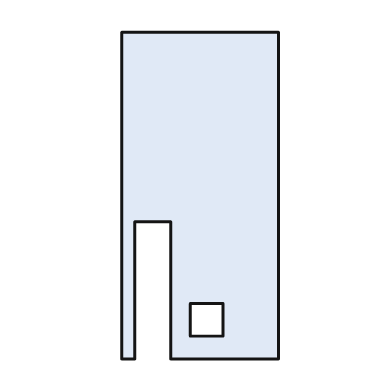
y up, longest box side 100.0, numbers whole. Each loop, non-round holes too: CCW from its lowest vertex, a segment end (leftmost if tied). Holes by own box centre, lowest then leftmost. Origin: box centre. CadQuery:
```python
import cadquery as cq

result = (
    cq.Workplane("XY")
    .moveTo(-24.0, -50.0)
    .lineTo(-20.0, -50.0)
    .lineTo(-20.0, -8.0)
    .lineTo(-9.0, -8.0)
    .lineTo(-9.0, -50.0)
    .lineTo(24.0, -50.0)
    .lineTo(24.0, 50.0)
    .lineTo(-24.0, 50.0)
    .close()
    .moveTo(-3.0, -43.0)
    .lineTo(7.0, -43.0)
    .lineTo(7.0, -33.0)
    .lineTo(-3.0, -33.0)
    .close()
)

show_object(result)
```